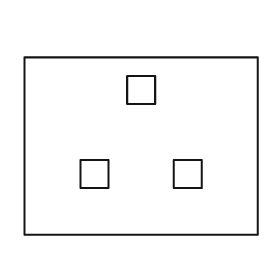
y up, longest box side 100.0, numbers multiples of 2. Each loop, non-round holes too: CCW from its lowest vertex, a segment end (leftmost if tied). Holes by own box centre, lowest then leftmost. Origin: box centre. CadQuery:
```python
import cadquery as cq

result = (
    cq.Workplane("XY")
    .moveTo(-50.0, -38.0)
    .lineTo(50.0, -38.0)
    .lineTo(50.0, 38.0)
    .lineTo(-50.0, 38.0)
    .close()
    .moveTo(-26.0, -18.0)
    .lineTo(-14.0, -18.0)
    .lineTo(-14.0, -6.0)
    .lineTo(-26.0, -6.0)
    .close()
    .moveTo(14.0, -18.0)
    .lineTo(26.0, -18.0)
    .lineTo(26.0, -6.0)
    .lineTo(14.0, -6.0)
    .close()
    .moveTo(-6.0, 18.0)
    .lineTo(6.0, 18.0)
    .lineTo(6.0, 30.0)
    .lineTo(-6.0, 30.0)
    .close()
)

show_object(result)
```